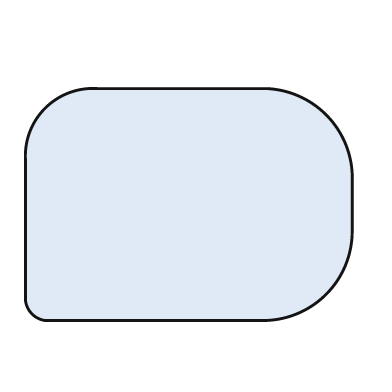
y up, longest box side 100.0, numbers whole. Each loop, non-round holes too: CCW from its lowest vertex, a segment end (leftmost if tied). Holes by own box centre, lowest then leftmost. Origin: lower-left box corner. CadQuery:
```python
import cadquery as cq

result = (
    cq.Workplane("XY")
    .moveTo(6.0, 0.0)
    .lineTo(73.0, 0.0)
    .threePointArc((92.0, 8.0), (100.0, 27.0))
    .lineTo(100.0, 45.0)
    .threePointArc((92.0, 63.0), (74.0, 71.0))
    .lineTo(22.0, 71.0)
    .threePointArc((6.0, 65.0), (0.0, 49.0))
    .lineTo(0.0, 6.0)
    .threePointArc((2.0, 2.0), (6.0, 0.0))
    .close()
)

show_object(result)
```